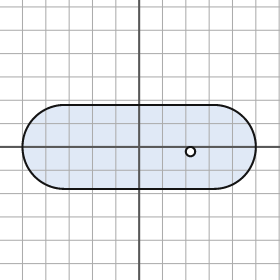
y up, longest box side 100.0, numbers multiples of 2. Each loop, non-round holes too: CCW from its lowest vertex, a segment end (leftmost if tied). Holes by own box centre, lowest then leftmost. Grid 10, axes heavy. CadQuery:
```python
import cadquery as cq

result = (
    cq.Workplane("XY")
    .moveTo(-32.0, -18.0)
    .lineTo(32.0, -18.0)
    .threePointArc((50.0, 0.0), (32.0, 18.0))
    .lineTo(-32.0, 18.0)
    .threePointArc((-50.0, 0.0), (-32.0, -18.0))
    .close()
    .moveTo(22.0, -2.0)
    .circle(2.0)
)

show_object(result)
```